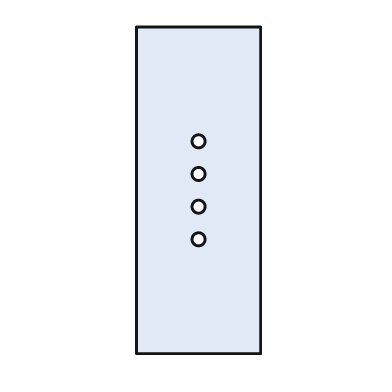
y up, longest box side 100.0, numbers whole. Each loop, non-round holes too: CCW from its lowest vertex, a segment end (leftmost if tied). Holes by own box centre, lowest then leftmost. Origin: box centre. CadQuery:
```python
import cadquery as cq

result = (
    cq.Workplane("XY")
    .moveTo(-19.0, -50.0)
    .lineTo(19.0, -50.0)
    .lineTo(19.0, 50.0)
    .lineTo(-19.0, 50.0)
    .close()
    .moveTo(0.0, -15.0)
    .circle(2.0)
    .moveTo(0.0, -5.0)
    .circle(2.0)
    .moveTo(0.0, 5.0)
    .circle(2.0)
    .moveTo(0.0, 15.0)
    .circle(2.0)
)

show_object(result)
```